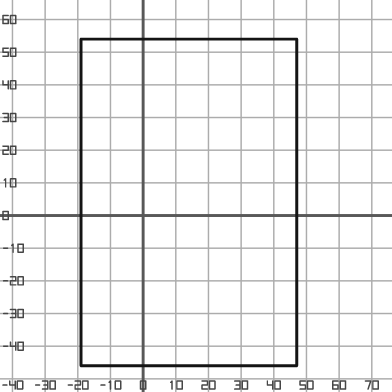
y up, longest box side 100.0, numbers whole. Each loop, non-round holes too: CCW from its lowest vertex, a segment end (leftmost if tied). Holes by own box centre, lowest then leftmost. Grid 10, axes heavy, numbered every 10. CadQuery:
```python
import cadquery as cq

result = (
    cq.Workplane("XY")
    .moveTo(-19.0, -46.0)
    .lineTo(47.0, -46.0)
    .lineTo(47.0, 54.0)
    .lineTo(-19.0, 54.0)
    .close()
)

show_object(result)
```